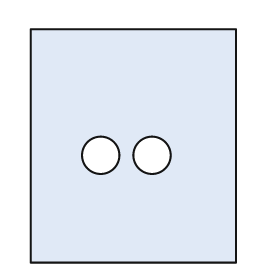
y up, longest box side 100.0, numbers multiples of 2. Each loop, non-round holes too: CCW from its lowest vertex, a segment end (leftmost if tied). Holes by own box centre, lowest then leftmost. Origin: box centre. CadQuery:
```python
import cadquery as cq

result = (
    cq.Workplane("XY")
    .moveTo(-44.0, -50.0)
    .lineTo(44.0, -50.0)
    .lineTo(44.0, 50.0)
    .lineTo(-44.0, 50.0)
    .close()
    .moveTo(-14.0, -4.0)
    .circle(8.0)
    .moveTo(8.0, -4.0)
    .circle(8.0)
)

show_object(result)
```